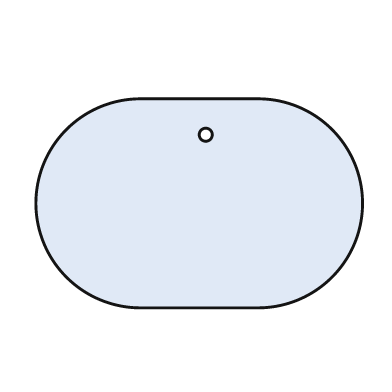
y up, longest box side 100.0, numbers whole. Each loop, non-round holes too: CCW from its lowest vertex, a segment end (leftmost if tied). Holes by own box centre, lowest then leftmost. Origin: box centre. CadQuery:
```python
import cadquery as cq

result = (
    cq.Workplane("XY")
    .moveTo(-18.0, -32.0)
    .lineTo(18.0, -32.0)
    .threePointArc((50.0, 0.0), (18.0, 32.0))
    .lineTo(-18.0, 32.0)
    .threePointArc((-50.0, 0.0), (-18.0, -32.0))
    .close()
    .moveTo(2.0, 21.0)
    .circle(2.0)
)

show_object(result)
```